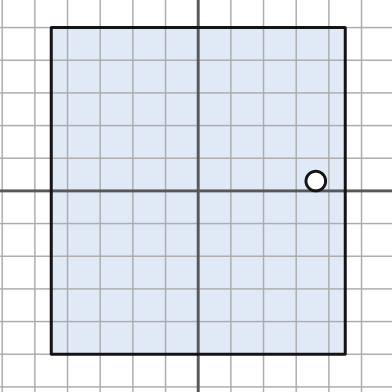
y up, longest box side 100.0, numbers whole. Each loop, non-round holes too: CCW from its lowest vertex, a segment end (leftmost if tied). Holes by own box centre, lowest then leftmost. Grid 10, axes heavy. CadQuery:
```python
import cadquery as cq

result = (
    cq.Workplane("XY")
    .moveTo(-45.0, -50.0)
    .lineTo(45.0, -50.0)
    .lineTo(45.0, 50.0)
    .lineTo(-45.0, 50.0)
    .close()
    .moveTo(36.0, 3.0)
    .circle(3.0)
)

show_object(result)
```